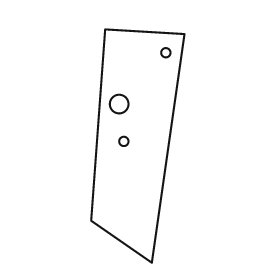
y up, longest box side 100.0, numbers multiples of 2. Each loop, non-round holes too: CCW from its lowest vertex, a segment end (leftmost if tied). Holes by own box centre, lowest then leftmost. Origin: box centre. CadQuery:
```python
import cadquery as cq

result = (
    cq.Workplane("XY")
    .moveTo(6.0, -50.0)
    .lineTo(20.0, 48.0)
    .lineTo(-14.0, 50.0)
    .lineTo(-20.0, -32.0)
    .close()
    .moveTo(-6.0, 2.0)
    .circle(2.0)
    .moveTo(-8.0, 18.0)
    .circle(4.0)
    .moveTo(12.0, 40.0)
    .circle(2.0)
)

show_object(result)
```